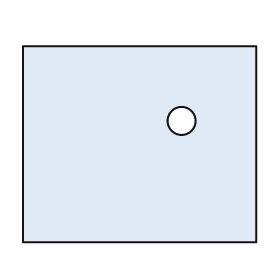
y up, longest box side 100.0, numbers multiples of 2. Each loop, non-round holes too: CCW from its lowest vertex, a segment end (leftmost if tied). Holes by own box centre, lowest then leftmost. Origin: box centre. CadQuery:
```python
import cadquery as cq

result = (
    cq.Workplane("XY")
    .moveTo(-50.0, -42.0)
    .lineTo(50.0, -42.0)
    .lineTo(50.0, 42.0)
    .lineTo(-50.0, 42.0)
    .close()
    .moveTo(18.0, 10.0)
    .circle(6.0)
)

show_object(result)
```